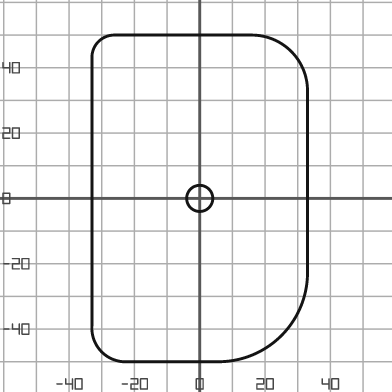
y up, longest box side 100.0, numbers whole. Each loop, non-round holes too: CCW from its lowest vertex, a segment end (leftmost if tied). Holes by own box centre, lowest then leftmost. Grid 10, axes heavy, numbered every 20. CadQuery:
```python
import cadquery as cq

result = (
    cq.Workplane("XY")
    .moveTo(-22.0, -50.0)
    .lineTo(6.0, -50.0)
    .threePointArc((25.0, -42.0), (33.0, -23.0))
    .lineTo(33.0, 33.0)
    .threePointArc((28.0, 45.0), (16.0, 50.0))
    .lineTo(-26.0, 50.0)
    .threePointArc((-31.0, 48.0), (-33.0, 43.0))
    .lineTo(-33.0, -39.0)
    .threePointArc((-30.0, -47.0), (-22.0, -50.0))
    .close()
    .moveTo(0.0, 0.0)
    .circle(4.0)
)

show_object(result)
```